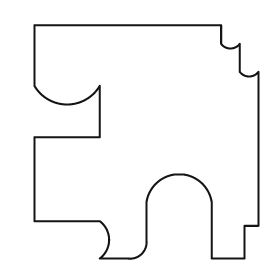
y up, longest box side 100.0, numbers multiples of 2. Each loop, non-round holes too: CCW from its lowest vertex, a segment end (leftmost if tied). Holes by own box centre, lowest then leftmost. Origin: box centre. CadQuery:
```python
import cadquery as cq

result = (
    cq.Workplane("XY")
    .moveTo(-20.0, -50.0)
    .lineTo(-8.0, -50.0)
    .threePointArc((-2.0, -48.0), (0.0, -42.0))
    .lineTo(0.0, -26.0)
    .threePointArc((4.0, -18.0), (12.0, -14.0))
    .lineTo(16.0, -14.0)
    .threePointArc((24.0, -18.0), (28.0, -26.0))
    .lineTo(28.0, -50.0)
    .lineTo(42.0, -50.0)
    .lineTo(42.0, -36.0)
    .lineTo(48.0, -36.0)
    .lineTo(48.0, 30.0)
    .threePointArc((44.0, 28.0), (40.0, 30.0))
    .lineTo(40.0, 42.0)
    .threePointArc((36.0, 40.0), (32.0, 42.0))
    .lineTo(32.0, 50.0)
    .lineTo(-48.0, 50.0)
    .lineTo(-48.0, 24.0)
    .threePointArc((-34.0, 16.0), (-20.0, 24.0))
    .lineTo(-20.0, 2.0)
    .lineTo(-48.0, 2.0)
    .lineTo(-48.0, -34.0)
    .lineTo(-20.0, -34.0)
    .threePointArc((-16.0, -42.0), (-20.0, -50.0))
    .close()
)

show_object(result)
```